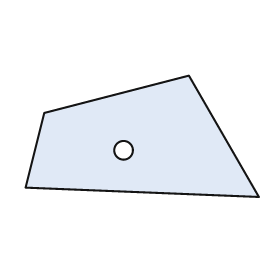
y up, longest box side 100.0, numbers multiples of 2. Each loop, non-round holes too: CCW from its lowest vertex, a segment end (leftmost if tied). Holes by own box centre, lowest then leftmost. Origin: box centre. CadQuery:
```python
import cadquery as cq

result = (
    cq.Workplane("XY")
    .moveTo(50.0, -26.0)
    .lineTo(20.0, 26.0)
    .lineTo(-42.0, 10.0)
    .lineTo(-50.0, -22.0)
    .close()
    .moveTo(-8.0, -6.0)
    .circle(4.0)
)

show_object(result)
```